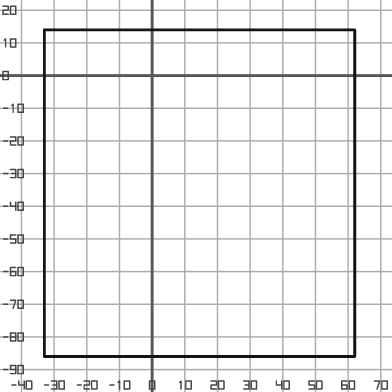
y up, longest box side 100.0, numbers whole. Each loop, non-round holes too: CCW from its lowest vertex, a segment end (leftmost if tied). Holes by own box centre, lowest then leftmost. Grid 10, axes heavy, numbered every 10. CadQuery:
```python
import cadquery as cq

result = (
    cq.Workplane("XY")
    .moveTo(-33.0, -86.0)
    .lineTo(62.0, -86.0)
    .lineTo(62.0, 14.0)
    .lineTo(-33.0, 14.0)
    .close()
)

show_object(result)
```